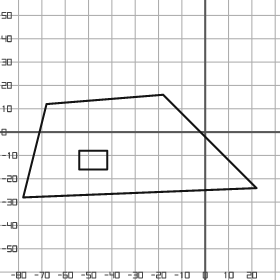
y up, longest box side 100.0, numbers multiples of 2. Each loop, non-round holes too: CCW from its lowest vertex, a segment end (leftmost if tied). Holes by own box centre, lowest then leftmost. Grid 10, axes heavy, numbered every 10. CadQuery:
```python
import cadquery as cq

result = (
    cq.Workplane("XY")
    .moveTo(-78.0, -28.0)
    .lineTo(22.0, -24.0)
    .lineTo(-18.0, 16.0)
    .lineTo(-68.0, 12.0)
    .close()
    .moveTo(-54.0, -16.0)
    .lineTo(-42.0, -16.0)
    .lineTo(-42.0, -8.0)
    .lineTo(-54.0, -8.0)
    .close()
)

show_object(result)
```